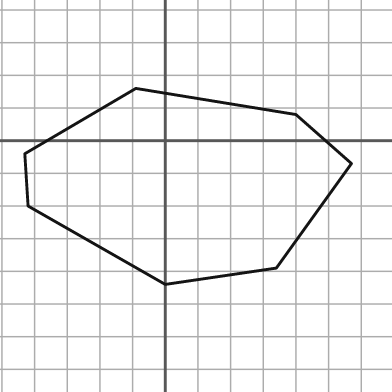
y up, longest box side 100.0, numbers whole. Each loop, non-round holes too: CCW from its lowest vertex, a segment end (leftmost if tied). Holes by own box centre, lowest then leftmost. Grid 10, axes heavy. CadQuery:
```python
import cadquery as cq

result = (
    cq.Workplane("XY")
    .moveTo(0.0, -44.0)
    .lineTo(34.0, -39.0)
    .lineTo(57.0, -7.0)
    .lineTo(40.0, 8.0)
    .lineTo(-9.0, 16.0)
    .lineTo(-43.0, -4.0)
    .lineTo(-42.0, -20.0)
    .close()
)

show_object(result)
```